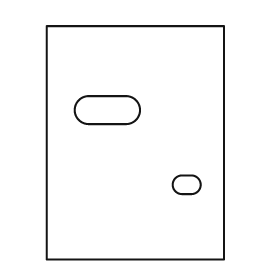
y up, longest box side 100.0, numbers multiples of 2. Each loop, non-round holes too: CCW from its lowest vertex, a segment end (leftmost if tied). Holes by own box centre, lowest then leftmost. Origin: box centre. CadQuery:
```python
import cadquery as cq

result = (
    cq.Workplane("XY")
    .moveTo(-38.0, -50.0)
    .lineTo(38.0, -50.0)
    .lineTo(38.0, 50.0)
    .lineTo(-38.0, 50.0)
    .close()
    .moveTo(20.0, -22.0)
    .lineTo(24.0, -22.0)
    .threePointArc((28.0, -18.0), (24.0, -14.0))
    .lineTo(20.0, -14.0)
    .threePointArc((16.0, -18.0), (20.0, -22.0))
    .close()
    .moveTo(-20.0, 8.0)
    .lineTo(-4.0, 8.0)
    .threePointArc((2.0, 14.0), (-4.0, 20.0))
    .lineTo(-20.0, 20.0)
    .threePointArc((-26.0, 14.0), (-20.0, 8.0))
    .close()
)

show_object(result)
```